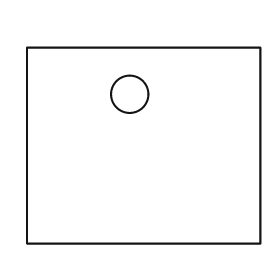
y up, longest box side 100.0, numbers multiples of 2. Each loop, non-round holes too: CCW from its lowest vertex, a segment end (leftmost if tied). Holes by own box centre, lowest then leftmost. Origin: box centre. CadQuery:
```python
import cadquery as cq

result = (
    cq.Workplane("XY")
    .moveTo(-50.0, -42.0)
    .lineTo(50.0, -42.0)
    .lineTo(50.0, 42.0)
    .lineTo(-50.0, 42.0)
    .close()
    .moveTo(-6.0, 22.0)
    .circle(8.0)
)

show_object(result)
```